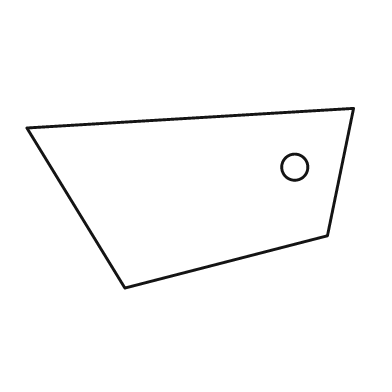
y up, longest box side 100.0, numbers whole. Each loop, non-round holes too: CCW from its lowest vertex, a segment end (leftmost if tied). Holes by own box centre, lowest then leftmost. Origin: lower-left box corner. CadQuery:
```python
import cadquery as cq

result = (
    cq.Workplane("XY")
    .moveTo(30.0, 0.0)
    .lineTo(92.0, 16.0)
    .lineTo(100.0, 55.0)
    .lineTo(0.0, 49.0)
    .close()
    .moveTo(82.0, 37.0)
    .circle(4.0)
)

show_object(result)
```